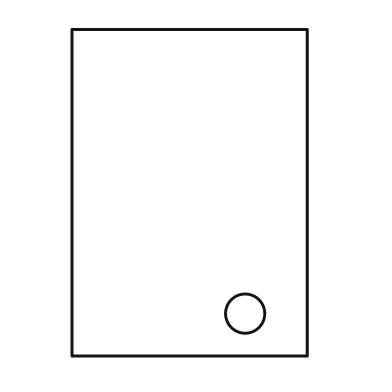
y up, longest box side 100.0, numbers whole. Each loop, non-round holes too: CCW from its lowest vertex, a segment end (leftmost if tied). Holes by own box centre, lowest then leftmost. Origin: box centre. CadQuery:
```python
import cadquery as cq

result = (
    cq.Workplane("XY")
    .moveTo(-36.0, -50.0)
    .lineTo(36.0, -50.0)
    .lineTo(36.0, 50.0)
    .lineTo(-36.0, 50.0)
    .close()
    .moveTo(17.0, -37.0)
    .circle(6.0)
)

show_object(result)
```